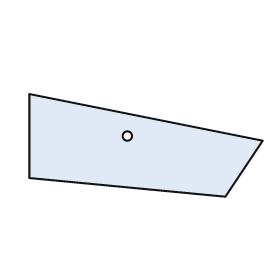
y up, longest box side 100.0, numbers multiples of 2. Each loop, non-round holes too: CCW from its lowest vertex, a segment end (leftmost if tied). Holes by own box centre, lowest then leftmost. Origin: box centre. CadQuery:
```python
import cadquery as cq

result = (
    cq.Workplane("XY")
    .moveTo(34.0, -22.0)
    .lineTo(50.0, 2.0)
    .lineTo(-50.0, 22.0)
    .lineTo(-50.0, -14.0)
    .close()
    .moveTo(-8.0, 4.0)
    .circle(2.0)
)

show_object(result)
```